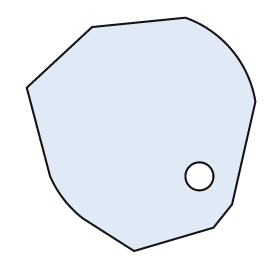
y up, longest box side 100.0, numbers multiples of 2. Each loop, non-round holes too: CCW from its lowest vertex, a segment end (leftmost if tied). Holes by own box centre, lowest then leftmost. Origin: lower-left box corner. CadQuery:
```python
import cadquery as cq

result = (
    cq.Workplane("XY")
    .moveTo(46.0, 0.0)
    .lineTo(80.0, 10.0)
    .lineTo(88.0, 20.0)
    .lineTo(98.0, 64.0)
    .threePointArc((88.0, 86.0), (68.0, 100.0))
    .lineTo(28.0, 96.0)
    .lineTo(0.0, 70.0)
    .lineTo(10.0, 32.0)
    .threePointArc((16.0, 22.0), (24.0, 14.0))
    .close()
    .moveTo(74.0, 32.0)
    .circle(6.0)
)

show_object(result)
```